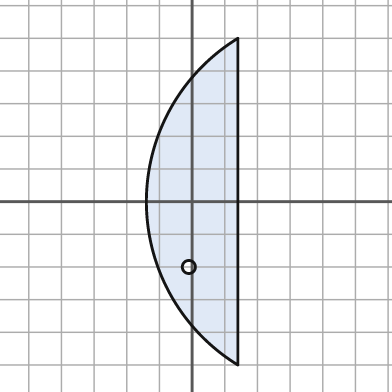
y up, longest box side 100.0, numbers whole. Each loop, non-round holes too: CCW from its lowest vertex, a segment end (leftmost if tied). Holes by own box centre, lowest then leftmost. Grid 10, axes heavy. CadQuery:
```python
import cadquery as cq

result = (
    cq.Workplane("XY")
    .moveTo(14.0, -50.0)
    .lineTo(14.0, 50.0)
    .threePointArc((-14.0, 0.0), (14.0, -50.0))
    .close()
    .moveTo(-1.0, -20.0)
    .circle(2.0)
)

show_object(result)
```